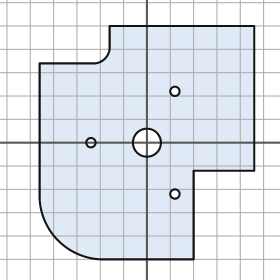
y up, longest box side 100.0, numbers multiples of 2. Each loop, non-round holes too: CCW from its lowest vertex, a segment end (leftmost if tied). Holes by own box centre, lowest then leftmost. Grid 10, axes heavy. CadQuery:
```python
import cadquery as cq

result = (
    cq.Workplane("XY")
    .moveTo(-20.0, -50.0)
    .lineTo(20.0, -50.0)
    .lineTo(20.0, -12.0)
    .lineTo(46.0, -12.0)
    .lineTo(46.0, 50.0)
    .lineTo(-16.0, 50.0)
    .lineTo(-16.0, 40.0)
    .threePointArc((-18.0, 36.0), (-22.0, 34.0))
    .lineTo(-46.0, 34.0)
    .lineTo(-46.0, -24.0)
    .threePointArc((-38.0, -42.0), (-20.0, -50.0))
    .close()
    .moveTo(12.0, -22.0)
    .circle(2.0)
    .moveTo(-24.0, 0.0)
    .circle(2.0)
    .moveTo(0.0, 0.0)
    .circle(6.0)
    .moveTo(12.0, 22.0)
    .circle(2.0)
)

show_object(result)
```